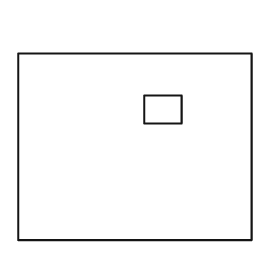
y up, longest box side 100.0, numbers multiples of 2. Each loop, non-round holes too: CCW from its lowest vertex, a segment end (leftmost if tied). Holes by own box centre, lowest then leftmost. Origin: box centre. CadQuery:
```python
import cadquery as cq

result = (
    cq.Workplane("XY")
    .moveTo(-50.0, -40.0)
    .lineTo(50.0, -40.0)
    .lineTo(50.0, 40.0)
    .lineTo(-50.0, 40.0)
    .close()
    .moveTo(4.0, 10.0)
    .lineTo(20.0, 10.0)
    .lineTo(20.0, 22.0)
    .lineTo(4.0, 22.0)
    .close()
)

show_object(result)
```